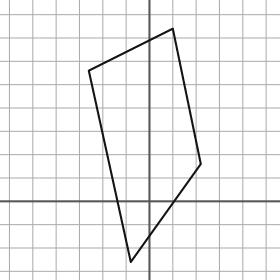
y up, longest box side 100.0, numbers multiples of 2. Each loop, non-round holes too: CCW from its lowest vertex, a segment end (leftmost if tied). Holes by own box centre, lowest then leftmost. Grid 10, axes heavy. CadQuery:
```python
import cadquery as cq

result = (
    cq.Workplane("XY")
    .moveTo(-8.0, -26.0)
    .lineTo(22.0, 16.0)
    .lineTo(10.0, 74.0)
    .lineTo(-26.0, 56.0)
    .close()
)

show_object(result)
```